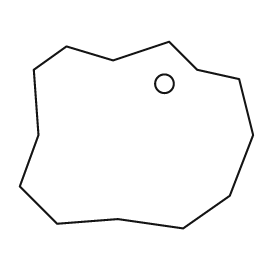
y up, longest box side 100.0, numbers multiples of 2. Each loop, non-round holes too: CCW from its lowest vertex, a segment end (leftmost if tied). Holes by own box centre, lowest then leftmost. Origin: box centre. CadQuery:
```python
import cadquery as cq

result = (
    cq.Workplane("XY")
    .moveTo(20.0, -40.0)
    .lineTo(40.0, -26.0)
    .lineTo(50.0, 0.0)
    .lineTo(44.0, 24.0)
    .lineTo(26.0, 28.0)
    .lineTo(14.0, 40.0)
    .lineTo(-10.0, 32.0)
    .lineTo(-30.0, 38.0)
    .lineTo(-44.0, 28.0)
    .lineTo(-42.0, 0.0)
    .lineTo(-50.0, -22.0)
    .lineTo(-34.0, -38.0)
    .lineTo(-8.0, -36.0)
    .close()
    .moveTo(12.0, 22.0)
    .circle(4.0)
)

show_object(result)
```